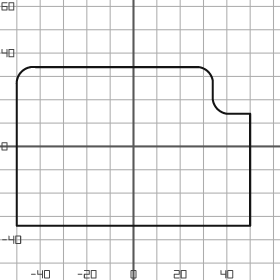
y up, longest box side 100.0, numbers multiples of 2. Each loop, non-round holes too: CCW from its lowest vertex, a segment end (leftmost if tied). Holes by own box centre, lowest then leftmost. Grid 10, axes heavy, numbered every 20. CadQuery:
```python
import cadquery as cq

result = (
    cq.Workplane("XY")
    .moveTo(-50.0, -34.0)
    .lineTo(50.0, -34.0)
    .lineTo(50.0, 14.0)
    .lineTo(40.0, 14.0)
    .threePointArc((36.0, 16.0), (34.0, 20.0))
    .lineTo(34.0, 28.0)
    .threePointArc((32.0, 32.0), (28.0, 34.0))
    .lineTo(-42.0, 34.0)
    .threePointArc((-48.0, 32.0), (-50.0, 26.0))
    .close()
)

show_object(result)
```